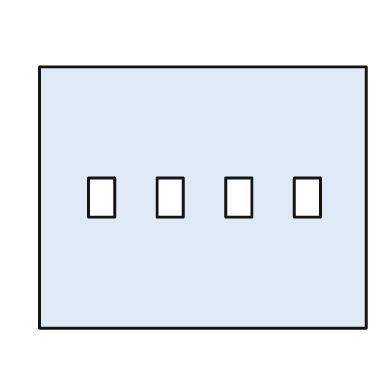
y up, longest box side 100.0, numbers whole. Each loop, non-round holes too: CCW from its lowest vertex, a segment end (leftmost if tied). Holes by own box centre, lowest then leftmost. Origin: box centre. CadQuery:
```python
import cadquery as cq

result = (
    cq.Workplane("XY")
    .moveTo(-50.0, -40.0)
    .lineTo(50.0, -40.0)
    .lineTo(50.0, 40.0)
    .lineTo(-50.0, 40.0)
    .close()
    .moveTo(-35.0, -6.0)
    .lineTo(-27.0, -6.0)
    .lineTo(-27.0, 6.0)
    .lineTo(-35.0, 6.0)
    .close()
    .moveTo(-14.0, -6.0)
    .lineTo(-6.0, -6.0)
    .lineTo(-6.0, 6.0)
    .lineTo(-14.0, 6.0)
    .close()
    .moveTo(7.0, -6.0)
    .lineTo(15.0, -6.0)
    .lineTo(15.0, 6.0)
    .lineTo(7.0, 6.0)
    .close()
    .moveTo(28.0, -6.0)
    .lineTo(36.0, -6.0)
    .lineTo(36.0, 6.0)
    .lineTo(28.0, 6.0)
    .close()
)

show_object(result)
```